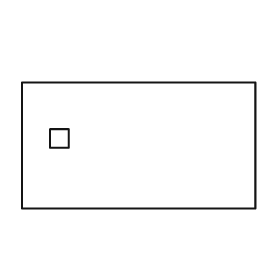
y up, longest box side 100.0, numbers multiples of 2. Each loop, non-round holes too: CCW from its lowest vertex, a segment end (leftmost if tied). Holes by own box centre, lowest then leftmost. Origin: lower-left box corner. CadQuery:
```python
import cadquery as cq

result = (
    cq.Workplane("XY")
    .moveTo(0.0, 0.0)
    .lineTo(100.0, 0.0)
    .lineTo(100.0, 54.0)
    .lineTo(0.0, 54.0)
    .close()
    .moveTo(12.0, 26.0)
    .lineTo(20.0, 26.0)
    .lineTo(20.0, 34.0)
    .lineTo(12.0, 34.0)
    .close()
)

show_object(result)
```